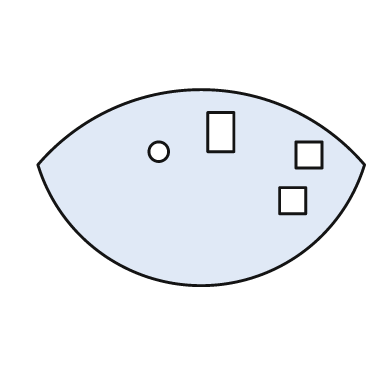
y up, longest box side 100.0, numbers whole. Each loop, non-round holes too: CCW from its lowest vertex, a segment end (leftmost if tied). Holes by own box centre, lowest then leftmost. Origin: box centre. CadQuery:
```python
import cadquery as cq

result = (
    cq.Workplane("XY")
    .moveTo(-50.0, 7.0)
    .threePointArc((0.0, -30.0), (50.0, 7.0))
    .threePointArc((0.0, 30.0), (-50.0, 7.0))
    .close()
    .moveTo(24.0, -8.0)
    .lineTo(32.0, -8.0)
    .lineTo(32.0, 0.0)
    .lineTo(24.0, 0.0)
    .close()
    .moveTo(29.0, 6.0)
    .lineTo(37.0, 6.0)
    .lineTo(37.0, 14.0)
    .lineTo(29.0, 14.0)
    .close()
    .moveTo(-13.0, 11.0)
    .circle(3.0)
    .moveTo(2.0, 11.0)
    .lineTo(10.0, 11.0)
    .lineTo(10.0, 23.0)
    .lineTo(2.0, 23.0)
    .close()
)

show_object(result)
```